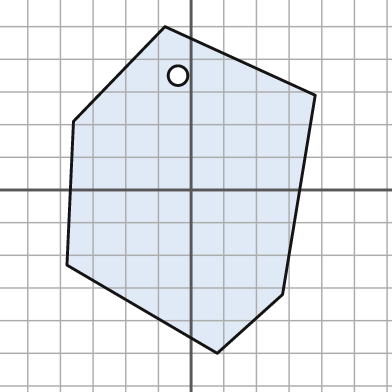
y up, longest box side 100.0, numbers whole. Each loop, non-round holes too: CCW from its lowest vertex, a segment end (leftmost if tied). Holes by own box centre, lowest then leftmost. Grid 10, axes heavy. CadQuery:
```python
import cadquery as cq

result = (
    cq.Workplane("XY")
    .moveTo(8.0, -50.0)
    .lineTo(28.0, -32.0)
    .lineTo(38.0, 29.0)
    .lineTo(-8.0, 50.0)
    .lineTo(-36.0, 21.0)
    .lineTo(-38.0, -23.0)
    .close()
    .moveTo(-4.0, 35.0)
    .circle(3.0)
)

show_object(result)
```